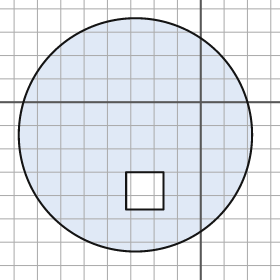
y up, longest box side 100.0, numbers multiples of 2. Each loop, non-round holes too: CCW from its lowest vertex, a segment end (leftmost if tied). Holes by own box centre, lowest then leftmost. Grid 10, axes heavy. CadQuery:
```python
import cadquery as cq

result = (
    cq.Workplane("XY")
    .moveTo(-28.0, -14.0)
    .circle(50.0)
    .moveTo(-32.0, -46.0)
    .lineTo(-16.0, -46.0)
    .lineTo(-16.0, -30.0)
    .lineTo(-32.0, -30.0)
    .close()
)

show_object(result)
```